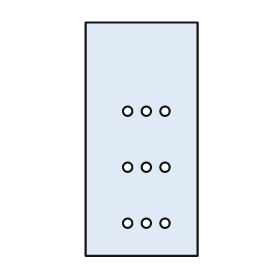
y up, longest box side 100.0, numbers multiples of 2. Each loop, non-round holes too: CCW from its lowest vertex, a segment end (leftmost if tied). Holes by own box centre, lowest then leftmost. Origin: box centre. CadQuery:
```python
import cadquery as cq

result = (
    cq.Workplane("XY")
    .moveTo(-24.0, -50.0)
    .lineTo(24.0, -50.0)
    .lineTo(24.0, 50.0)
    .lineTo(-24.0, 50.0)
    .close()
    .moveTo(-6.0, -36.0)
    .circle(2.0)
    .moveTo(2.0, -36.0)
    .circle(2.0)
    .moveTo(10.0, -36.0)
    .circle(2.0)
    .moveTo(-6.0, -12.0)
    .circle(2.0)
    .moveTo(2.0, -12.0)
    .circle(2.0)
    .moveTo(10.0, -12.0)
    .circle(2.0)
    .moveTo(-6.0, 12.0)
    .circle(2.0)
    .moveTo(2.0, 12.0)
    .circle(2.0)
    .moveTo(10.0, 12.0)
    .circle(2.0)
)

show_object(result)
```